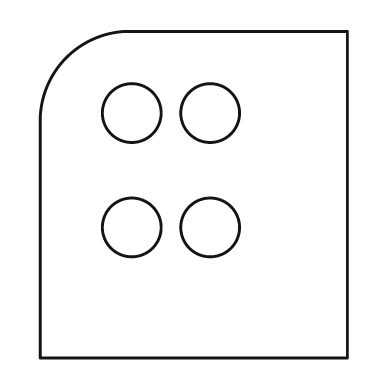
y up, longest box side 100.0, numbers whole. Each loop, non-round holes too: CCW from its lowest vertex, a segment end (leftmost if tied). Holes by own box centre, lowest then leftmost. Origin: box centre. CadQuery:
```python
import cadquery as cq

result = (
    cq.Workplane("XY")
    .moveTo(-47.0, -50.0)
    .lineTo(47.0, -50.0)
    .lineTo(47.0, 50.0)
    .lineTo(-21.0, 50.0)
    .threePointArc((-39.0, 42.0), (-47.0, 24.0))
    .close()
    .moveTo(-19.0, -10.0)
    .circle(9.0)
    .moveTo(5.0, -10.0)
    .circle(9.0)
    .moveTo(-19.0, 25.0)
    .circle(9.0)
    .moveTo(5.0, 25.0)
    .circle(9.0)
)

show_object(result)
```